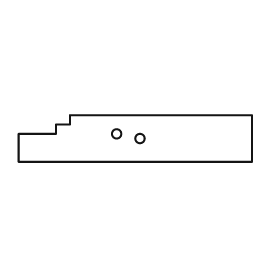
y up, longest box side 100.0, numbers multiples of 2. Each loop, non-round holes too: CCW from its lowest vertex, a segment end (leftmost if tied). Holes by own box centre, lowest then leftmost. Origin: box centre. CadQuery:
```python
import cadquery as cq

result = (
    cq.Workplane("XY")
    .moveTo(-50.0, -10.0)
    .lineTo(50.0, -10.0)
    .lineTo(50.0, 10.0)
    .lineTo(-28.0, 10.0)
    .lineTo(-28.0, 6.0)
    .lineTo(-34.0, 6.0)
    .lineTo(-34.0, 2.0)
    .lineTo(-50.0, 2.0)
    .close()
    .moveTo(2.0, 0.0)
    .circle(2.0)
    .moveTo(-8.0, 2.0)
    .circle(2.0)
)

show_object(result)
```